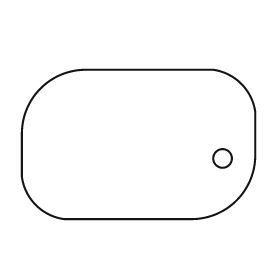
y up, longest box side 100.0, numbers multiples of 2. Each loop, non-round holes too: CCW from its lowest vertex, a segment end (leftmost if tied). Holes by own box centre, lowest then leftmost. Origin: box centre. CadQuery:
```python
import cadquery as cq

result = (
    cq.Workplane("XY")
    .moveTo(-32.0, -32.0)
    .lineTo(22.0, -32.0)
    .threePointArc((42.0, -24.0), (50.0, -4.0))
    .lineTo(50.0, 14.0)
    .threePointArc((44.0, 26.0), (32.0, 32.0))
    .lineTo(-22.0, 32.0)
    .threePointArc((-42.0, 24.0), (-50.0, 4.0))
    .lineTo(-50.0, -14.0)
    .threePointArc((-44.0, -26.0), (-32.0, -32.0))
    .close()
    .moveTo(36.0, -6.0)
    .circle(4.0)
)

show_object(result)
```